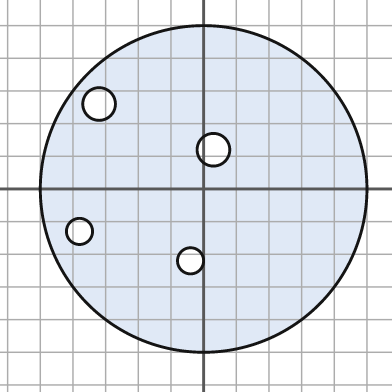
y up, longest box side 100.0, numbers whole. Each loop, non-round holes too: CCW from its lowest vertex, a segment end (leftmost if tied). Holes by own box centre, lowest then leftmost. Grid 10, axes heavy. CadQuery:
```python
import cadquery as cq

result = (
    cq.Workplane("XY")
    .moveTo(0.0, 0.0)
    .circle(50.0)
    .moveTo(-4.0, -22.0)
    .circle(4.0)
    .moveTo(-38.0, -13.0)
    .circle(4.0)
    .moveTo(3.0, 12.0)
    .circle(5.0)
    .moveTo(-32.0, 26.0)
    .circle(5.0)
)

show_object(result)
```